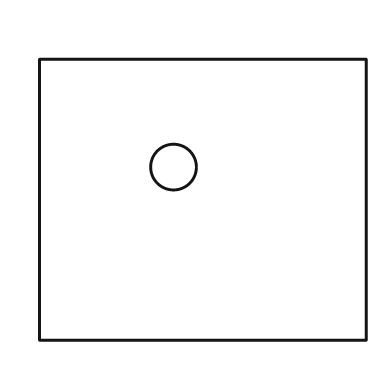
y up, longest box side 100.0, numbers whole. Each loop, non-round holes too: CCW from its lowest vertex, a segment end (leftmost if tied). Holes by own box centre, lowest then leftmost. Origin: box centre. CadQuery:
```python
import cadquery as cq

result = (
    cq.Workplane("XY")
    .moveTo(-50.0, -43.0)
    .lineTo(50.0, -43.0)
    .lineTo(50.0, 43.0)
    .lineTo(-50.0, 43.0)
    .close()
    .moveTo(-9.0, 10.0)
    .circle(7.0)
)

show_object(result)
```